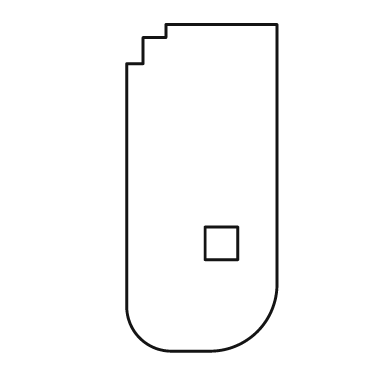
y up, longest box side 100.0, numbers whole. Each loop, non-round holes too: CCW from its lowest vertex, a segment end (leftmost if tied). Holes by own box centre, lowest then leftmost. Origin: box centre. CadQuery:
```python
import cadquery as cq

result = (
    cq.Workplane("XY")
    .moveTo(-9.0, -50.0)
    .lineTo(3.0, -50.0)
    .threePointArc((17.0, -44.0), (23.0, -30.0))
    .lineTo(23.0, 50.0)
    .lineTo(-11.0, 50.0)
    .lineTo(-11.0, 46.0)
    .lineTo(-18.0, 46.0)
    .lineTo(-18.0, 38.0)
    .lineTo(-23.0, 38.0)
    .lineTo(-23.0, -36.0)
    .threePointArc((-19.0, -46.0), (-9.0, -50.0))
    .close()
    .moveTo(1.0, -22.0)
    .lineTo(11.0, -22.0)
    .lineTo(11.0, -12.0)
    .lineTo(1.0, -12.0)
    .close()
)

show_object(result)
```